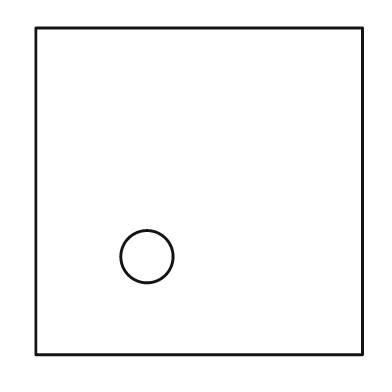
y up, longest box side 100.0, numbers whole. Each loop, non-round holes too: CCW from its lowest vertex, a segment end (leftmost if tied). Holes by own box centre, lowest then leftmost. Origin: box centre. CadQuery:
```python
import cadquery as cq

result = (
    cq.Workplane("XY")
    .moveTo(-50.0, -50.0)
    .lineTo(50.0, -50.0)
    .lineTo(50.0, 50.0)
    .lineTo(-50.0, 50.0)
    .close()
    .moveTo(-16.0, -20.0)
    .circle(8.0)
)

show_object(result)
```